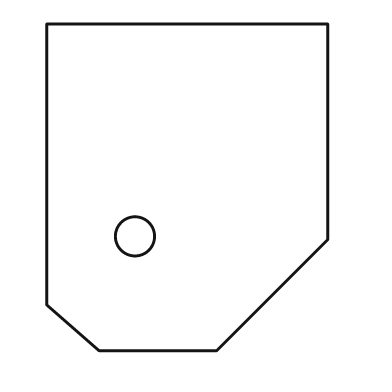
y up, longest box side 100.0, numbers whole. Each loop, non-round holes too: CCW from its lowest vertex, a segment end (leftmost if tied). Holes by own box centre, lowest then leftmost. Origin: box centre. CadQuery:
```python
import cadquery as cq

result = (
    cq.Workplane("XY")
    .moveTo(-27.0, -50.0)
    .lineTo(9.0, -50.0)
    .lineTo(43.0, -16.0)
    .lineTo(43.0, 50.0)
    .lineTo(-43.0, 50.0)
    .lineTo(-43.0, -36.0)
    .close()
    .moveTo(-16.0, -15.0)
    .circle(6.0)
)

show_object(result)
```